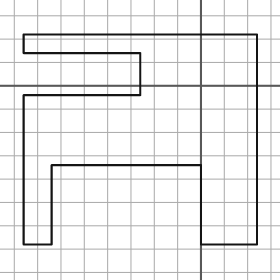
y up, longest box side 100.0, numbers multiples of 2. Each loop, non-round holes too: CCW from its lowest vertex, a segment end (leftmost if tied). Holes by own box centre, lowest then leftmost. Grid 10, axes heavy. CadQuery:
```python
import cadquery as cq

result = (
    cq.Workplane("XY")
    .moveTo(-76.0, -68.0)
    .lineTo(-64.0, -68.0)
    .lineTo(-64.0, -34.0)
    .lineTo(0.0, -34.0)
    .lineTo(0.0, -68.0)
    .lineTo(24.0, -68.0)
    .lineTo(24.0, 22.0)
    .lineTo(-76.0, 22.0)
    .lineTo(-76.0, 14.0)
    .lineTo(-26.0, 14.0)
    .lineTo(-26.0, -4.0)
    .lineTo(-76.0, -4.0)
    .close()
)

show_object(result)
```